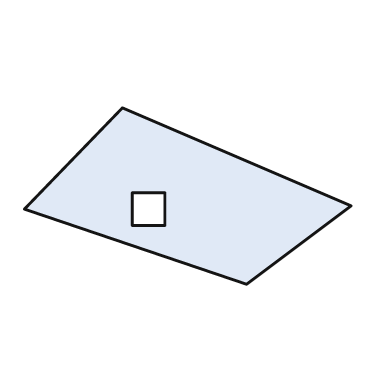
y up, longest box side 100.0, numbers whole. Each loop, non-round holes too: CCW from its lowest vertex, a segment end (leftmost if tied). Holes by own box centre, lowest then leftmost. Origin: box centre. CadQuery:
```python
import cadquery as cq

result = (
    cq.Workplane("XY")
    .moveTo(18.0, -27.0)
    .lineTo(50.0, -3.0)
    .lineTo(-20.0, 27.0)
    .lineTo(-50.0, -4.0)
    .close()
    .moveTo(-17.0, -9.0)
    .lineTo(-7.0, -9.0)
    .lineTo(-7.0, 1.0)
    .lineTo(-17.0, 1.0)
    .close()
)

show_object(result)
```